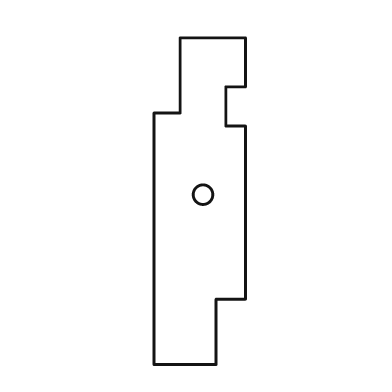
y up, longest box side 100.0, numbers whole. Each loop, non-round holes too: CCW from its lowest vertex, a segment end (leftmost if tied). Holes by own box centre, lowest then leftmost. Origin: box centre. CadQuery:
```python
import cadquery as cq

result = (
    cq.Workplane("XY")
    .moveTo(-14.0, -50.0)
    .lineTo(5.0, -50.0)
    .lineTo(5.0, -30.0)
    .lineTo(14.0, -30.0)
    .lineTo(14.0, 23.0)
    .lineTo(8.0, 23.0)
    .lineTo(8.0, 35.0)
    .lineTo(14.0, 35.0)
    .lineTo(14.0, 50.0)
    .lineTo(-6.0, 50.0)
    .lineTo(-6.0, 27.0)
    .lineTo(-14.0, 27.0)
    .close()
    .moveTo(1.0, 2.0)
    .circle(3.0)
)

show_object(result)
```